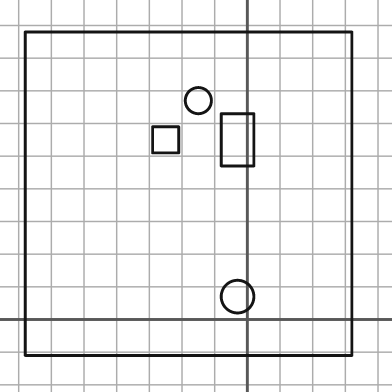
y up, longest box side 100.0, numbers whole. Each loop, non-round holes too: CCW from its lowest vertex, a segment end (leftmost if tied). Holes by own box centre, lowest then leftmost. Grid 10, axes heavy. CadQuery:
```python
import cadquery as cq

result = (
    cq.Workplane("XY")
    .moveTo(-68.0, -11.0)
    .lineTo(32.0, -11.0)
    .lineTo(32.0, 88.0)
    .lineTo(-68.0, 88.0)
    .close()
    .moveTo(-3.0, 7.0)
    .circle(5.0)
    .moveTo(-29.0, 51.0)
    .lineTo(-21.0, 51.0)
    .lineTo(-21.0, 59.0)
    .lineTo(-29.0, 59.0)
    .close()
    .moveTo(-8.0, 47.0)
    .lineTo(2.0, 47.0)
    .lineTo(2.0, 63.0)
    .lineTo(-8.0, 63.0)
    .close()
    .moveTo(-15.0, 67.0)
    .circle(4.0)
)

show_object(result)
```